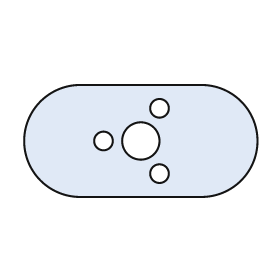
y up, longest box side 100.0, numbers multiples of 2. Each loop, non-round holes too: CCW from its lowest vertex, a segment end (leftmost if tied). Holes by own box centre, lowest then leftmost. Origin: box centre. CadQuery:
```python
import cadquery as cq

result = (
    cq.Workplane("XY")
    .moveTo(-26.0, -24.0)
    .lineTo(26.0, -24.0)
    .threePointArc((50.0, 0.0), (26.0, 24.0))
    .lineTo(-26.0, 24.0)
    .threePointArc((-50.0, 0.0), (-26.0, -24.0))
    .close()
    .moveTo(8.0, -14.0)
    .circle(4.0)
    .moveTo(-16.0, 0.0)
    .circle(4.0)
    .moveTo(0.0, 0.0)
    .circle(8.0)
    .moveTo(8.0, 14.0)
    .circle(4.0)
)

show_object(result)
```